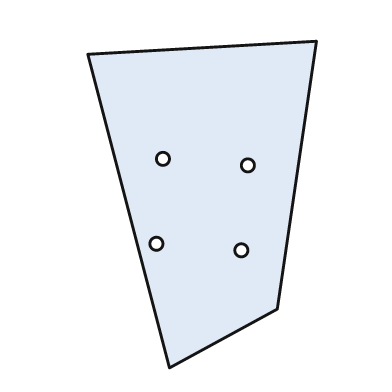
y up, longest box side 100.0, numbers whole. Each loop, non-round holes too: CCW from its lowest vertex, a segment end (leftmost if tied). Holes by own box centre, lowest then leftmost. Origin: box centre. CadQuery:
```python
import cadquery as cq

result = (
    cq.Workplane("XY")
    .moveTo(-10.0, -50.0)
    .lineTo(23.0, -32.0)
    .lineTo(35.0, 50.0)
    .lineTo(-35.0, 46.0)
    .close()
    .moveTo(12.0, -14.0)
    .circle(2.0)
    .moveTo(-14.0, -12.0)
    .circle(2.0)
    .moveTo(14.0, 12.0)
    .circle(2.0)
    .moveTo(-12.0, 14.0)
    .circle(2.0)
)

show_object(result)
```